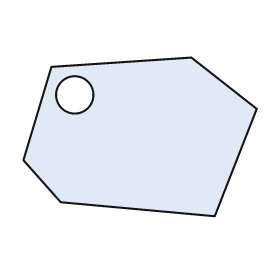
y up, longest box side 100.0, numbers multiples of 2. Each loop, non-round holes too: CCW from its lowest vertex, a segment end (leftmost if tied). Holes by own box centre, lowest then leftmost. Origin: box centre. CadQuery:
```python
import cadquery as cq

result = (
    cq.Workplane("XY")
    .moveTo(32.0, -34.0)
    .lineTo(50.0, 12.0)
    .lineTo(22.0, 34.0)
    .lineTo(-38.0, 30.0)
    .lineTo(-50.0, -10.0)
    .lineTo(-34.0, -28.0)
    .close()
    .moveTo(-28.0, 18.0)
    .circle(8.0)
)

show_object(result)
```